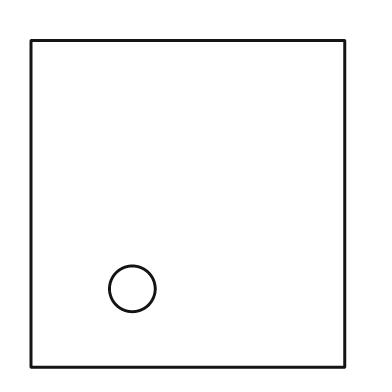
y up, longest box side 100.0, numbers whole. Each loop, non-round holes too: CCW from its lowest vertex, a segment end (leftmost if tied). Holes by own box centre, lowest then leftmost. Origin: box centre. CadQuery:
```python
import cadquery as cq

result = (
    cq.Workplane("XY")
    .moveTo(-48.0, -50.0)
    .lineTo(48.0, -50.0)
    .lineTo(48.0, 50.0)
    .lineTo(-48.0, 50.0)
    .close()
    .moveTo(-17.0, -26.0)
    .circle(7.0)
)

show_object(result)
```